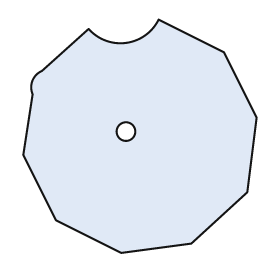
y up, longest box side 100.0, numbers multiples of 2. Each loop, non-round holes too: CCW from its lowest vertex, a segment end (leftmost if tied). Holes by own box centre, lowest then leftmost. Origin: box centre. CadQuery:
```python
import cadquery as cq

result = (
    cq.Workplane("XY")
    .moveTo(-8.0, -50.0)
    .lineTo(22.0, -46.0)
    .lineTo(46.0, -24.0)
    .lineTo(50.0, 8.0)
    .lineTo(36.0, 36.0)
    .lineTo(8.0, 50.0)
    .threePointArc((-6.0, 40.0), (-22.0, 46.0))
    .lineTo(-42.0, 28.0)
    .threePointArc((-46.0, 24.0), (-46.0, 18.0))
    .lineTo(-50.0, -8.0)
    .lineTo(-36.0, -36.0)
    .close()
    .moveTo(-6.0, 2.0)
    .circle(4.0)
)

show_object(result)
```